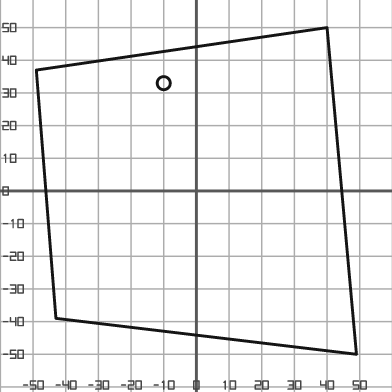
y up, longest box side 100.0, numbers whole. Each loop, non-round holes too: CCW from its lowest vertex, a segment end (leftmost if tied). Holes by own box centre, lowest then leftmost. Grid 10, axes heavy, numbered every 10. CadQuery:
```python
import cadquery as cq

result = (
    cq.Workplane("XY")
    .moveTo(49.0, -50.0)
    .lineTo(40.0, 50.0)
    .lineTo(-49.0, 37.0)
    .lineTo(-43.0, -39.0)
    .close()
    .moveTo(-10.0, 33.0)
    .circle(2.0)
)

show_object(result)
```